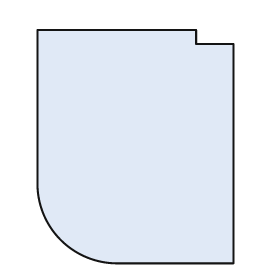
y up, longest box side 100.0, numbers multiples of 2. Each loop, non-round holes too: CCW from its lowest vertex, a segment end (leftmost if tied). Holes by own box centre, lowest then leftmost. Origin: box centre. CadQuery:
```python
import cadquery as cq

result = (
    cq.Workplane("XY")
    .moveTo(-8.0, -50.0)
    .lineTo(42.0, -50.0)
    .lineTo(42.0, 44.0)
    .lineTo(26.0, 44.0)
    .lineTo(26.0, 50.0)
    .lineTo(-42.0, 50.0)
    .lineTo(-42.0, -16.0)
    .threePointArc((-32.0, -40.0), (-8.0, -50.0))
    .close()
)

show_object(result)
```